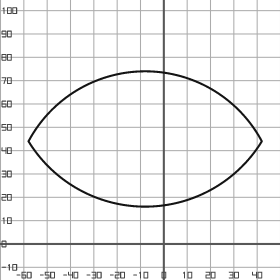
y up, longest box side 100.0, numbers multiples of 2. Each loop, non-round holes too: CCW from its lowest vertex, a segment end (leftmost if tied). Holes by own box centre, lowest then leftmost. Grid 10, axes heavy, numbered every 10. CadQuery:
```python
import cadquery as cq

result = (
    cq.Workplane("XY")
    .moveTo(-58.0, 44.0)
    .threePointArc((-8.0, 16.0), (42.0, 44.0))
    .threePointArc((-8.0, 74.0), (-58.0, 44.0))
    .close()
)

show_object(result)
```